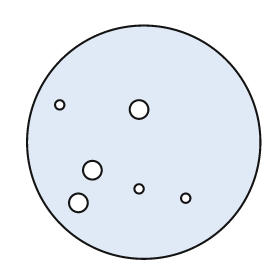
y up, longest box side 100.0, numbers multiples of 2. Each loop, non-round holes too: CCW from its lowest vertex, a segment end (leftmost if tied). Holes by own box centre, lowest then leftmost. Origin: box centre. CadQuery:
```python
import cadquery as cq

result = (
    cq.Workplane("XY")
    .moveTo(0.0, 0.0)
    .circle(50.0)
    .moveTo(-28.0, -26.0)
    .circle(4.0)
    .moveTo(18.0, -24.0)
    .circle(2.0)
    .moveTo(-2.0, -20.0)
    .circle(2.0)
    .moveTo(-22.0, -12.0)
    .circle(4.0)
    .moveTo(-2.0, 14.0)
    .circle(4.0)
    .moveTo(-36.0, 16.0)
    .circle(2.0)
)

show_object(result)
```